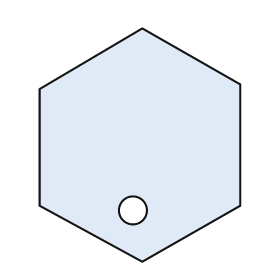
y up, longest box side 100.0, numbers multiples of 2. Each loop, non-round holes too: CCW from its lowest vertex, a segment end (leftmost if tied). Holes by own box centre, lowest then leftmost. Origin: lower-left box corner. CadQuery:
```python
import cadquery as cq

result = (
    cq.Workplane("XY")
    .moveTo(44.0, 0.0)
    .lineTo(86.0, 24.0)
    .lineTo(86.0, 76.0)
    .lineTo(44.0, 100.0)
    .lineTo(0.0, 74.0)
    .lineTo(0.0, 24.0)
    .close()
    .moveTo(40.0, 22.0)
    .circle(6.0)
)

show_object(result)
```